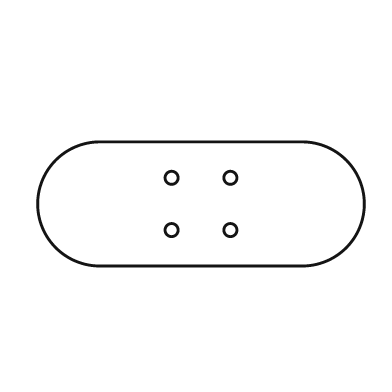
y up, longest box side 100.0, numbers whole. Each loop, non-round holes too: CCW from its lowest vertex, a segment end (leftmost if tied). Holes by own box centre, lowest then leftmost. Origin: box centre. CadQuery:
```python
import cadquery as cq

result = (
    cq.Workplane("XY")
    .moveTo(-31.0, -19.0)
    .lineTo(31.0, -19.0)
    .threePointArc((50.0, 0.0), (31.0, 19.0))
    .lineTo(-31.0, 19.0)
    .threePointArc((-50.0, 0.0), (-31.0, -19.0))
    .close()
    .moveTo(-9.0, -8.0)
    .circle(2.0)
    .moveTo(9.0, -8.0)
    .circle(2.0)
    .moveTo(-9.0, 8.0)
    .circle(2.0)
    .moveTo(9.0, 8.0)
    .circle(2.0)
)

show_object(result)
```